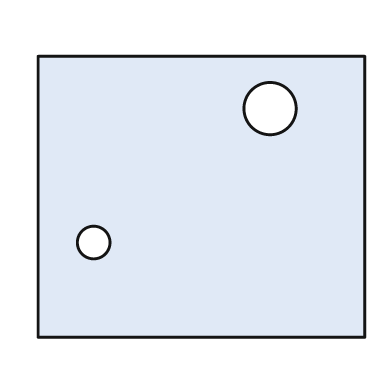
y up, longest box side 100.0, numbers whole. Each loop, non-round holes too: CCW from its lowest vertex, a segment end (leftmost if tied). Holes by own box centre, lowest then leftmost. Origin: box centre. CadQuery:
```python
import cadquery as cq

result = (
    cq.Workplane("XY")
    .moveTo(-50.0, -43.0)
    .lineTo(50.0, -43.0)
    .lineTo(50.0, 43.0)
    .lineTo(-50.0, 43.0)
    .close()
    .moveTo(-33.0, -14.0)
    .circle(5.0)
    .moveTo(21.0, 27.0)
    .circle(8.0)
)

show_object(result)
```